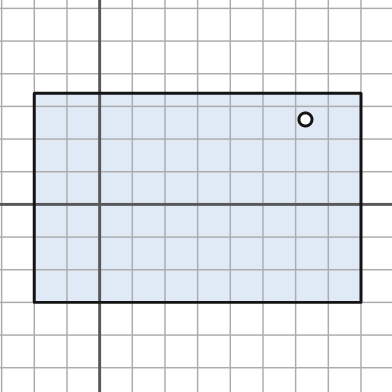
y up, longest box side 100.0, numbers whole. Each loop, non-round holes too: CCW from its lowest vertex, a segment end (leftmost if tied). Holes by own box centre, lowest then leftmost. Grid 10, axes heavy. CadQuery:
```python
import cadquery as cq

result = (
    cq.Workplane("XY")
    .moveTo(-20.0, -30.0)
    .lineTo(80.0, -30.0)
    .lineTo(80.0, 34.0)
    .lineTo(-20.0, 34.0)
    .close()
    .moveTo(63.0, 26.0)
    .circle(2.0)
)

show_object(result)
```